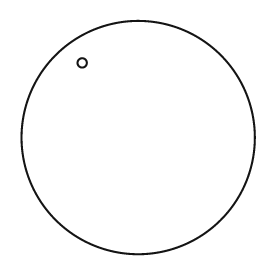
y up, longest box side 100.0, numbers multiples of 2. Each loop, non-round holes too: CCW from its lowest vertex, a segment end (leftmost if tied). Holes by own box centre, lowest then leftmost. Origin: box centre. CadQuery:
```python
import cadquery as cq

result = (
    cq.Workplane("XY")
    .moveTo(0.0, 0.0)
    .circle(50.0)
    .moveTo(-24.0, 32.0)
    .circle(2.0)
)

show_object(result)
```